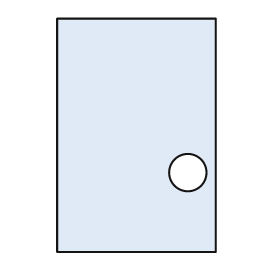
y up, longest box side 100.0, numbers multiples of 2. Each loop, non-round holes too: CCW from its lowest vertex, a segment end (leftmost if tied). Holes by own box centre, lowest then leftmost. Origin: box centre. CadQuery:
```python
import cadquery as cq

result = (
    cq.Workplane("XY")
    .moveTo(-34.0, -50.0)
    .lineTo(34.0, -50.0)
    .lineTo(34.0, 50.0)
    .lineTo(-34.0, 50.0)
    .close()
    .moveTo(22.0, -16.0)
    .circle(8.0)
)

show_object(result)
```